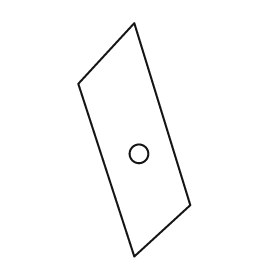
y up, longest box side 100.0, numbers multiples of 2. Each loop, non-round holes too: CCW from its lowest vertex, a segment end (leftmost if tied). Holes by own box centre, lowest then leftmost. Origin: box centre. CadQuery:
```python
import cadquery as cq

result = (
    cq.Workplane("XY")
    .moveTo(0.0, -50.0)
    .lineTo(24.0, -28.0)
    .lineTo(0.0, 50.0)
    .lineTo(-24.0, 24.0)
    .close()
    .moveTo(2.0, -6.0)
    .circle(4.0)
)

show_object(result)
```